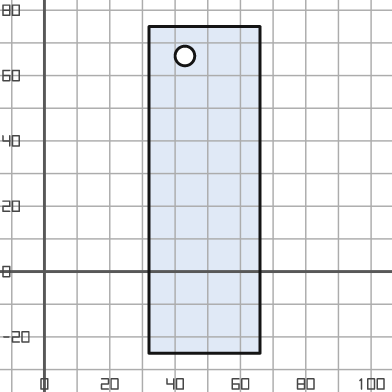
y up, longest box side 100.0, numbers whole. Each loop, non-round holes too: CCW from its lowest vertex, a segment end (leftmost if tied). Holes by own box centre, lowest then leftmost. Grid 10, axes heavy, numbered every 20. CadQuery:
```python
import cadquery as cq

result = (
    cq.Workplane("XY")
    .moveTo(32.0, -25.0)
    .lineTo(66.0, -25.0)
    .lineTo(66.0, 75.0)
    .lineTo(32.0, 75.0)
    .close()
    .moveTo(43.0, 66.0)
    .circle(3.0)
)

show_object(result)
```